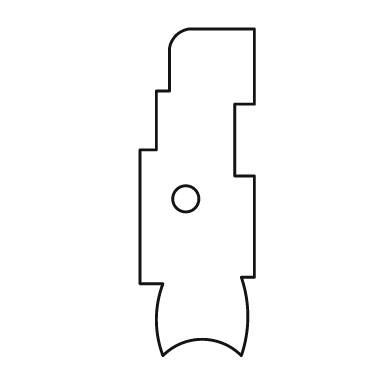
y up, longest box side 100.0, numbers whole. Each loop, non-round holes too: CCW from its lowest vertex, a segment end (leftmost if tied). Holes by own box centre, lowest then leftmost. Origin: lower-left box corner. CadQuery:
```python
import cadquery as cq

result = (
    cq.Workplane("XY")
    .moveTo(7.0, 0.0)
    .threePointArc((19.0, 5.0), (31.0, 0.0))
    .threePointArc((33.0, 12.0), (31.0, 24.0))
    .lineTo(35.0, 24.0)
    .lineTo(35.0, 55.0)
    .lineTo(29.0, 55.0)
    .lineTo(29.0, 77.0)
    .lineTo(35.0, 77.0)
    .lineTo(35.0, 100.0)
    .lineTo(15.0, 100.0)
    .threePointArc((11.0, 98.0), (9.0, 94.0))
    .lineTo(9.0, 81.0)
    .lineTo(5.0, 81.0)
    .lineTo(5.0, 63.0)
    .lineTo(0.0, 63.0)
    .lineTo(0.0, 22.0)
    .lineTo(7.0, 22.0)
    .threePointArc((5.0, 11.0), (7.0, 0.0))
    .close()
    .moveTo(14.0, 48.0)
    .circle(4.0)
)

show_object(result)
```